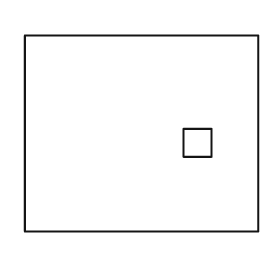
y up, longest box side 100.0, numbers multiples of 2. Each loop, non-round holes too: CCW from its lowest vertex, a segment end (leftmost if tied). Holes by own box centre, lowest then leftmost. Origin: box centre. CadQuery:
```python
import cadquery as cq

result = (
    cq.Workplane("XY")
    .moveTo(-50.0, -42.0)
    .lineTo(50.0, -42.0)
    .lineTo(50.0, 42.0)
    .lineTo(-50.0, 42.0)
    .close()
    .moveTo(18.0, -10.0)
    .lineTo(30.0, -10.0)
    .lineTo(30.0, 2.0)
    .lineTo(18.0, 2.0)
    .close()
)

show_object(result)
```